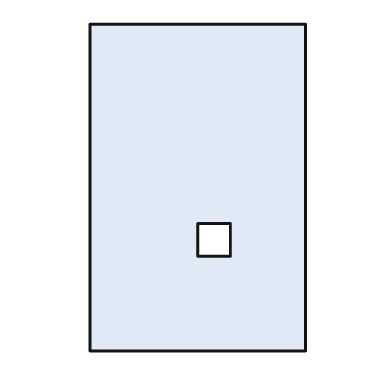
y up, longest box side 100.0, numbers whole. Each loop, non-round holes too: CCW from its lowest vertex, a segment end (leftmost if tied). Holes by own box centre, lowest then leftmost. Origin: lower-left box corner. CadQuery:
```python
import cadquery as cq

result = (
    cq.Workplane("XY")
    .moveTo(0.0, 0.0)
    .lineTo(66.0, 0.0)
    .lineTo(66.0, 100.0)
    .lineTo(0.0, 100.0)
    .close()
    .moveTo(33.0, 29.0)
    .lineTo(43.0, 29.0)
    .lineTo(43.0, 39.0)
    .lineTo(33.0, 39.0)
    .close()
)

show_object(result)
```